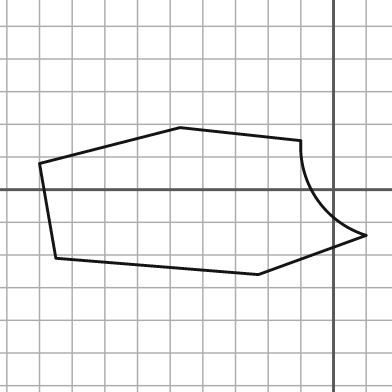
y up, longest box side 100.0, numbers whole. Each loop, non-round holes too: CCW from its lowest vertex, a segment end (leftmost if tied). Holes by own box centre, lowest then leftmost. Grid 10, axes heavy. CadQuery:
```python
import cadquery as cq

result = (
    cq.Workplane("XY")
    .moveTo(-23.0, -26.0)
    .lineTo(10.0, -14.0)
    .threePointArc((-5.0, -3.0), (-10.0, 15.0))
    .lineTo(-47.0, 19.0)
    .lineTo(-90.0, 8.0)
    .lineTo(-85.0, -21.0)
    .close()
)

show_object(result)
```